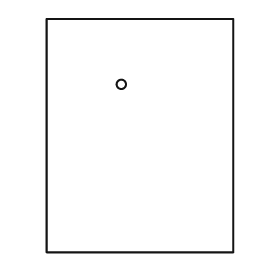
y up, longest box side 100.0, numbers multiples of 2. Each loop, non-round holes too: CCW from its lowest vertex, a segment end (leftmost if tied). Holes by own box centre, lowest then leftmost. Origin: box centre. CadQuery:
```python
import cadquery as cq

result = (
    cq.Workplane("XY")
    .moveTo(-40.0, -50.0)
    .lineTo(40.0, -50.0)
    .lineTo(40.0, 50.0)
    .lineTo(-40.0, 50.0)
    .close()
    .moveTo(-8.0, 22.0)
    .circle(2.0)
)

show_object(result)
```